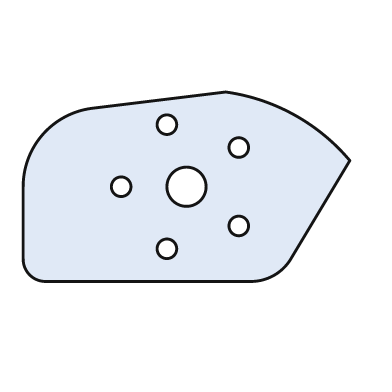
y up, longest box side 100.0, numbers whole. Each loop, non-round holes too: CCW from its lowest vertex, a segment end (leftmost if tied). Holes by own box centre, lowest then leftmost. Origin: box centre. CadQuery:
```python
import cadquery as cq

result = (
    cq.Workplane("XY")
    .moveTo(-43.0, -29.0)
    .lineTo(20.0, -29.0)
    .threePointArc((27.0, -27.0), (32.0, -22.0))
    .lineTo(50.0, 8.0)
    .threePointArc((33.0, 22.0), (12.0, 29.0))
    .lineTo(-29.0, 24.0)
    .threePointArc((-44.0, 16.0), (-50.0, 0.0))
    .lineTo(-50.0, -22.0)
    .threePointArc((-48.0, -27.0), (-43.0, -29.0))
    .close()
    .moveTo(-6.0, -19.0)
    .circle(3.0)
    .moveTo(16.0, -12.0)
    .circle(3.0)
    .moveTo(-20.0, 0.0)
    .circle(3.0)
    .moveTo(0.0, 0.0)
    .circle(6.0)
    .moveTo(16.0, 12.0)
    .circle(3.0)
    .moveTo(-6.0, 19.0)
    .circle(3.0)
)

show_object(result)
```